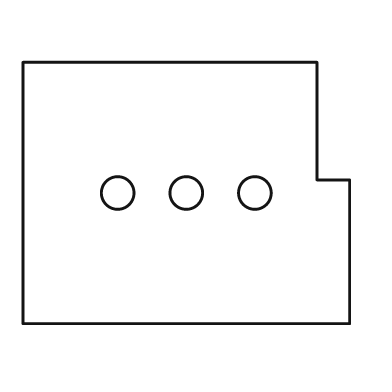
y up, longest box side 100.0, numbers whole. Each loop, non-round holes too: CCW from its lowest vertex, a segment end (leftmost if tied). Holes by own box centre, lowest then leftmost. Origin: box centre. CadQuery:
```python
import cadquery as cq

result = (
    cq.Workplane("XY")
    .moveTo(-50.0, -40.0)
    .lineTo(50.0, -40.0)
    .lineTo(50.0, 4.0)
    .lineTo(40.0, 4.0)
    .lineTo(40.0, 40.0)
    .lineTo(-50.0, 40.0)
    .close()
    .moveTo(-21.0, 0.0)
    .circle(5.0)
    .moveTo(0.0, 0.0)
    .circle(5.0)
    .moveTo(21.0, 0.0)
    .circle(5.0)
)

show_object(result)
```